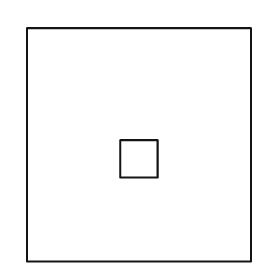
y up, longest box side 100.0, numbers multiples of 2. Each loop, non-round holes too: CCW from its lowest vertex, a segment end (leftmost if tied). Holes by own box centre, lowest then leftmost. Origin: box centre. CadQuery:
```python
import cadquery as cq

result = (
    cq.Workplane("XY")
    .moveTo(-48.0, -50.0)
    .lineTo(48.0, -50.0)
    .lineTo(48.0, 50.0)
    .lineTo(-48.0, 50.0)
    .close()
    .moveTo(-8.0, -14.0)
    .lineTo(8.0, -14.0)
    .lineTo(8.0, 2.0)
    .lineTo(-8.0, 2.0)
    .close()
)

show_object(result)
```